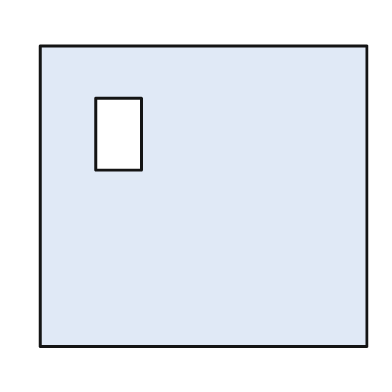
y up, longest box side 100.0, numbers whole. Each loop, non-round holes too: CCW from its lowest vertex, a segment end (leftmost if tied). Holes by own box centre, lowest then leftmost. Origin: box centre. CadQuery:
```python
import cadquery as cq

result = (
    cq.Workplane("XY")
    .moveTo(-50.0, -46.0)
    .lineTo(50.0, -46.0)
    .lineTo(50.0, 46.0)
    .lineTo(-50.0, 46.0)
    .close()
    .moveTo(-33.0, 8.0)
    .lineTo(-19.0, 8.0)
    .lineTo(-19.0, 30.0)
    .lineTo(-33.0, 30.0)
    .close()
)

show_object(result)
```